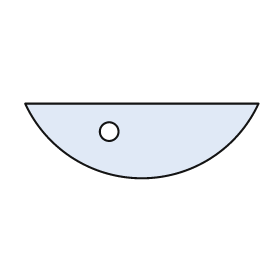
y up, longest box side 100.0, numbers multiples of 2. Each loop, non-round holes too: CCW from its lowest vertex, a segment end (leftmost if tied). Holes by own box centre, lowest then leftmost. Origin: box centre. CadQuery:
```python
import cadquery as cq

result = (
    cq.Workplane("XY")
    .moveTo(-50.0, 16.0)
    .threePointArc((0.0, -16.0), (50.0, 16.0))
    .close()
    .moveTo(-14.0, 4.0)
    .circle(4.0)
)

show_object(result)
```